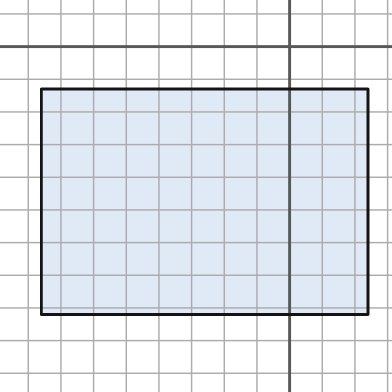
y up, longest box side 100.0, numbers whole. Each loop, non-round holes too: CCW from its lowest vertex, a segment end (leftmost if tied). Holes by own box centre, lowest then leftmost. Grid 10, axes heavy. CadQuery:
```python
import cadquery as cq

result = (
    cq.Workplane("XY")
    .moveTo(-76.0, -82.0)
    .lineTo(24.0, -82.0)
    .lineTo(24.0, -13.0)
    .lineTo(-76.0, -13.0)
    .close()
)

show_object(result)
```